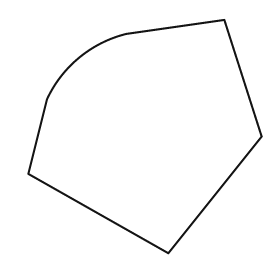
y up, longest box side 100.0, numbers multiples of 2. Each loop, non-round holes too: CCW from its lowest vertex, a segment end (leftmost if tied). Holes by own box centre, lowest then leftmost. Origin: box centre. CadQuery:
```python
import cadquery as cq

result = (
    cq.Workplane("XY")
    .moveTo(10.0, -50.0)
    .lineTo(50.0, 0.0)
    .lineTo(34.0, 50.0)
    .lineTo(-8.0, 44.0)
    .threePointArc((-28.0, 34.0), (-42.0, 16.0))
    .lineTo(-50.0, -16.0)
    .close()
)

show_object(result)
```